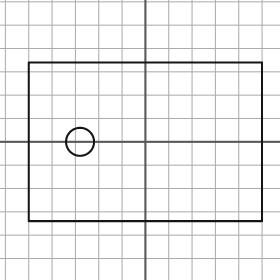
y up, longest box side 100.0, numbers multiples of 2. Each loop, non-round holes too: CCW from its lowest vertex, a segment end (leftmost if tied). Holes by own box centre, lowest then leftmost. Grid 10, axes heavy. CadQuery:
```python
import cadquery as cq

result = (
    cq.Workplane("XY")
    .moveTo(-50.0, -34.0)
    .lineTo(50.0, -34.0)
    .lineTo(50.0, 34.0)
    .lineTo(-50.0, 34.0)
    .close()
    .moveTo(-28.0, 0.0)
    .circle(6.0)
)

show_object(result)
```